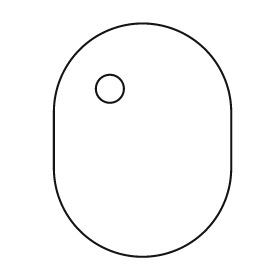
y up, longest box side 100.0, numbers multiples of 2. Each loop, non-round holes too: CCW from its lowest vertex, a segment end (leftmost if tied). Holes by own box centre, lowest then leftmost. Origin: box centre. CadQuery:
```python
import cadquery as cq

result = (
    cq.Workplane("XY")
    .moveTo(-38.0, -12.0)
    .threePointArc((0.0, -50.0), (38.0, -12.0))
    .lineTo(38.0, 12.0)
    .threePointArc((0.0, 50.0), (-38.0, 12.0))
    .close()
    .moveTo(-14.0, 22.0)
    .circle(6.0)
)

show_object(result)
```